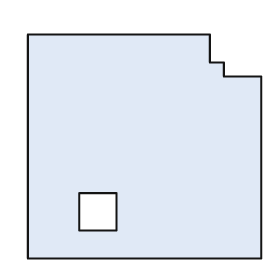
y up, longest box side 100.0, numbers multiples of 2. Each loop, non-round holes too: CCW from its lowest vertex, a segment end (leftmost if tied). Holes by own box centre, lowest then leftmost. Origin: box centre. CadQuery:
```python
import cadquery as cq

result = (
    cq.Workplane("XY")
    .moveTo(-50.0, -48.0)
    .lineTo(50.0, -48.0)
    .lineTo(50.0, 30.0)
    .lineTo(34.0, 30.0)
    .lineTo(34.0, 36.0)
    .lineTo(28.0, 36.0)
    .lineTo(28.0, 48.0)
    .lineTo(-50.0, 48.0)
    .close()
    .moveTo(-28.0, -36.0)
    .lineTo(-12.0, -36.0)
    .lineTo(-12.0, -20.0)
    .lineTo(-28.0, -20.0)
    .close()
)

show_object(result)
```